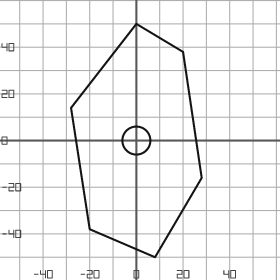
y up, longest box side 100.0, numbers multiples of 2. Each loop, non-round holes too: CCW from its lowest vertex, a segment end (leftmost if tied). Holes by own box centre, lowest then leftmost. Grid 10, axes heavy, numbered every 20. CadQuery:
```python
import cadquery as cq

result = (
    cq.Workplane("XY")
    .moveTo(8.0, -50.0)
    .lineTo(28.0, -16.0)
    .lineTo(20.0, 38.0)
    .lineTo(0.0, 50.0)
    .lineTo(-28.0, 14.0)
    .lineTo(-20.0, -38.0)
    .close()
    .moveTo(0.0, 0.0)
    .circle(6.0)
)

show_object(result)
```